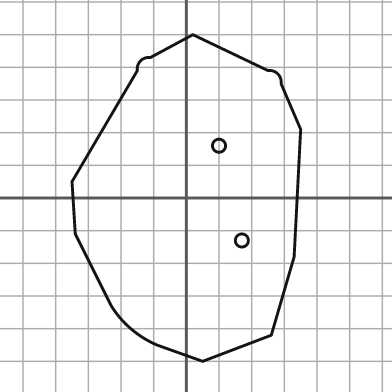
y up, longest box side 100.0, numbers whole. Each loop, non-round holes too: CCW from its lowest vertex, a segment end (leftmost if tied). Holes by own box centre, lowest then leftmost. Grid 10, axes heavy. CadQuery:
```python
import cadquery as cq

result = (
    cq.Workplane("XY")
    .moveTo(5.0, -50.0)
    .lineTo(26.0, -42.0)
    .lineTo(33.0, -18.0)
    .lineTo(35.0, 21.0)
    .lineTo(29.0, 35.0)
    .threePointArc((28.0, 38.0), (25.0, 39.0))
    .lineTo(2.0, 50.0)
    .lineTo(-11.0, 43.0)
    .threePointArc((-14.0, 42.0), (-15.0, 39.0))
    .lineTo(-35.0, 5.0)
    .lineTo(-34.0, -11.0)
    .lineTo(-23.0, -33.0)
    .threePointArc((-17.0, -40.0), (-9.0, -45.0))
    .close()
    .moveTo(17.0, -13.0)
    .circle(2.0)
    .moveTo(10.0, 16.0)
    .circle(2.0)
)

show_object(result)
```